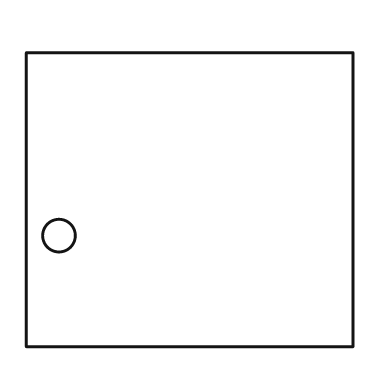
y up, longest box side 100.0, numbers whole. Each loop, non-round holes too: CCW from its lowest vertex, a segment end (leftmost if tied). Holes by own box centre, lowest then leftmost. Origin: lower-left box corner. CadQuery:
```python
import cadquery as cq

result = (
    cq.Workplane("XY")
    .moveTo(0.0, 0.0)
    .lineTo(100.0, 0.0)
    .lineTo(100.0, 90.0)
    .lineTo(0.0, 90.0)
    .close()
    .moveTo(10.0, 34.0)
    .circle(5.0)
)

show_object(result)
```